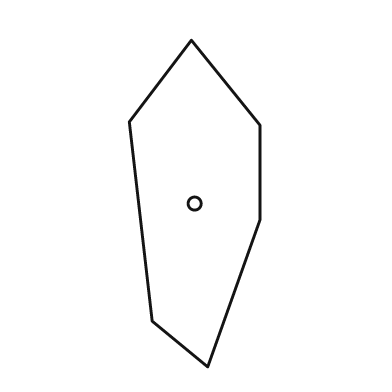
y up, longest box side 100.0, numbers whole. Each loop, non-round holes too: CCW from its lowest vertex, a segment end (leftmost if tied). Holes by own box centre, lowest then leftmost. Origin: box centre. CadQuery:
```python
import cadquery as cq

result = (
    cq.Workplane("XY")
    .moveTo(4.0, -50.0)
    .lineTo(20.0, -5.0)
    .lineTo(20.0, 24.0)
    .lineTo(-1.0, 50.0)
    .lineTo(-20.0, 25.0)
    .lineTo(-13.0, -36.0)
    .close()
    .moveTo(0.0, 0.0)
    .circle(2.0)
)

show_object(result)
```